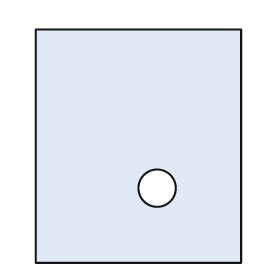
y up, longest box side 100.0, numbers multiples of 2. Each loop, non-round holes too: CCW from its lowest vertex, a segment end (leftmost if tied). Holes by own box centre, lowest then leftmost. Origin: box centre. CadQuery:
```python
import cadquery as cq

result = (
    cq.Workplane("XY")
    .moveTo(-44.0, -50.0)
    .lineTo(44.0, -50.0)
    .lineTo(44.0, 50.0)
    .lineTo(-44.0, 50.0)
    .close()
    .moveTo(8.0, -18.0)
    .circle(8.0)
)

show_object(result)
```